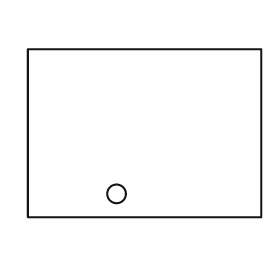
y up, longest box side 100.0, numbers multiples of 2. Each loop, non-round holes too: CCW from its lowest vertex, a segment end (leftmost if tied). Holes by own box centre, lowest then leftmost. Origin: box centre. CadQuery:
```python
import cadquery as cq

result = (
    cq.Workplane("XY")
    .moveTo(-50.0, -36.0)
    .lineTo(50.0, -36.0)
    .lineTo(50.0, 36.0)
    .lineTo(-50.0, 36.0)
    .close()
    .moveTo(-12.0, -26.0)
    .circle(4.0)
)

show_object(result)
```